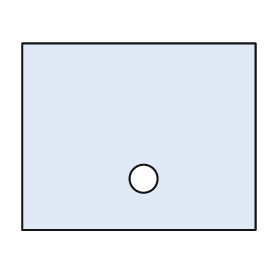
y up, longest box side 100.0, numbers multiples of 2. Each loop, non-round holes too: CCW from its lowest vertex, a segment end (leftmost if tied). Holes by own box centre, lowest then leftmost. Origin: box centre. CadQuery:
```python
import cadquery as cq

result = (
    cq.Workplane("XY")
    .moveTo(-50.0, -40.0)
    .lineTo(50.0, -40.0)
    .lineTo(50.0, 40.0)
    .lineTo(-50.0, 40.0)
    .close()
    .moveTo(2.0, -18.0)
    .circle(6.0)
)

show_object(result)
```